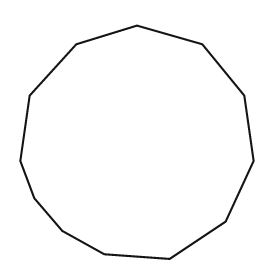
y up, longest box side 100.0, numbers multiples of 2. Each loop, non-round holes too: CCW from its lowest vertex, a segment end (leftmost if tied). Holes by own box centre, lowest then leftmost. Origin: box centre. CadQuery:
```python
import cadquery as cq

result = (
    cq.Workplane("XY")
    .moveTo(14.0, -50.0)
    .lineTo(38.0, -34.0)
    .lineTo(50.0, -8.0)
    .lineTo(46.0, 20.0)
    .lineTo(28.0, 42.0)
    .lineTo(0.0, 50.0)
    .lineTo(-26.0, 42.0)
    .lineTo(-46.0, 20.0)
    .lineTo(-50.0, -8.0)
    .lineTo(-44.0, -24.0)
    .lineTo(-32.0, -38.0)
    .lineTo(-14.0, -48.0)
    .close()
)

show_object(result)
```